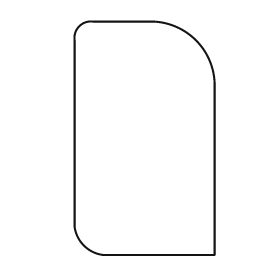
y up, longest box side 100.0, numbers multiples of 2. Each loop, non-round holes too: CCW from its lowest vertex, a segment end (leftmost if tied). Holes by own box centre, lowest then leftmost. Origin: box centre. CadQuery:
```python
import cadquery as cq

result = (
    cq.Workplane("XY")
    .moveTo(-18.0, -50.0)
    .lineTo(30.0, -50.0)
    .lineTo(30.0, 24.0)
    .threePointArc((22.0, 42.0), (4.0, 50.0))
    .lineTo(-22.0, 50.0)
    .threePointArc((-28.0, 48.0), (-30.0, 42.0))
    .lineTo(-30.0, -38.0)
    .threePointArc((-26.0, -46.0), (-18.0, -50.0))
    .close()
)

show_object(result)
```